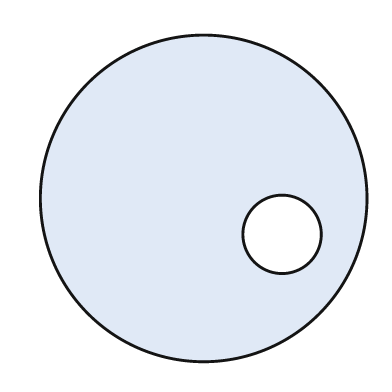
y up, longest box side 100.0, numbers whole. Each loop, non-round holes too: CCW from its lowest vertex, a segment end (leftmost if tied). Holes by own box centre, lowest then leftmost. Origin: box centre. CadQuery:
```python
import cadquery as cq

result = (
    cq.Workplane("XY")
    .moveTo(0.0, 0.0)
    .circle(50.0)
    .moveTo(24.0, -11.0)
    .circle(12.0)
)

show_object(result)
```